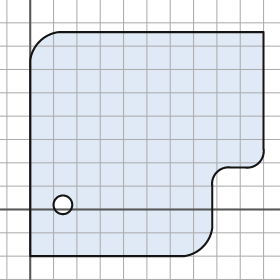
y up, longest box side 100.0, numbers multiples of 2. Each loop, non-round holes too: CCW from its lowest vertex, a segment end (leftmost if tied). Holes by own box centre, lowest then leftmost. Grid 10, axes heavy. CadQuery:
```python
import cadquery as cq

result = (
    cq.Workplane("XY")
    .moveTo(0.0, -20.0)
    .lineTo(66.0, -20.0)
    .threePointArc((74.0, -16.0), (78.0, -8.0))
    .lineTo(78.0, 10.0)
    .threePointArc((80.0, 16.0), (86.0, 18.0))
    .lineTo(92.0, 18.0)
    .threePointArc((98.0, 20.0), (100.0, 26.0))
    .lineTo(100.0, 76.0)
    .lineTo(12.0, 76.0)
    .threePointArc((4.0, 72.0), (0.0, 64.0))
    .close()
    .moveTo(14.0, 2.0)
    .circle(4.0)
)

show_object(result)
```